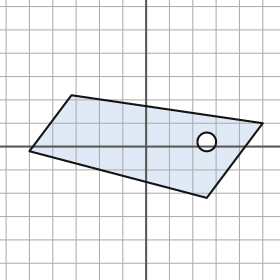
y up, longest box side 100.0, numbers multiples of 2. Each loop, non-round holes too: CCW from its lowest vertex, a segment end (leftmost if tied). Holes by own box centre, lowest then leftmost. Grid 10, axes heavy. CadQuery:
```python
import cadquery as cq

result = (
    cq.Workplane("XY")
    .moveTo(26.0, -22.0)
    .lineTo(50.0, 10.0)
    .lineTo(-32.0, 22.0)
    .lineTo(-50.0, -2.0)
    .close()
    .moveTo(26.0, 2.0)
    .circle(4.0)
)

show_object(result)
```